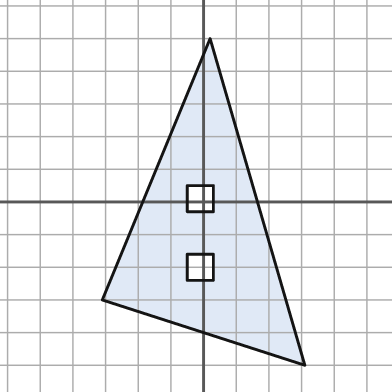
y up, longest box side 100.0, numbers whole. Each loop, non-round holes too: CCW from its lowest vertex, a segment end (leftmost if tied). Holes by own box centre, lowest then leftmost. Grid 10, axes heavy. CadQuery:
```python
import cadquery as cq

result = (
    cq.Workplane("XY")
    .moveTo(31.0, -50.0)
    .lineTo(2.0, 50.0)
    .lineTo(-31.0, -30.0)
    .close()
    .moveTo(-5.0, -24.0)
    .lineTo(3.0, -24.0)
    .lineTo(3.0, -16.0)
    .lineTo(-5.0, -16.0)
    .close()
    .moveTo(-5.0, -3.0)
    .lineTo(3.0, -3.0)
    .lineTo(3.0, 5.0)
    .lineTo(-5.0, 5.0)
    .close()
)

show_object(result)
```